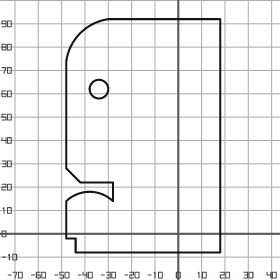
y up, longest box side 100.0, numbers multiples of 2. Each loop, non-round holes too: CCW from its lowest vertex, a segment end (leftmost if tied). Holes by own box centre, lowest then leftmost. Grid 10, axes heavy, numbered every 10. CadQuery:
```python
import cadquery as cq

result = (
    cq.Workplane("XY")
    .moveTo(-44.0, -8.0)
    .lineTo(18.0, -8.0)
    .lineTo(18.0, 92.0)
    .lineTo(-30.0, 92.0)
    .threePointArc((-42.0, 86.0), (-48.0, 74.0))
    .lineTo(-48.0, 28.0)
    .lineTo(-42.0, 22.0)
    .lineTo(-28.0, 22.0)
    .lineTo(-28.0, 14.0)
    .threePointArc((-38.0, 18.0), (-48.0, 14.0))
    .lineTo(-48.0, -2.0)
    .lineTo(-44.0, -2.0)
    .close()
    .moveTo(-34.0, 62.0)
    .circle(4.0)
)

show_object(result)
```